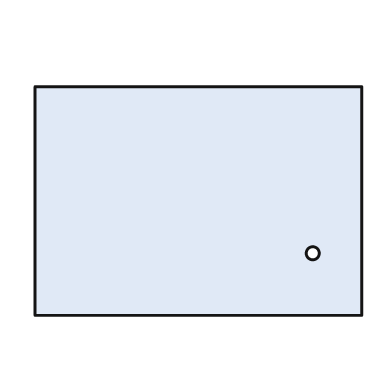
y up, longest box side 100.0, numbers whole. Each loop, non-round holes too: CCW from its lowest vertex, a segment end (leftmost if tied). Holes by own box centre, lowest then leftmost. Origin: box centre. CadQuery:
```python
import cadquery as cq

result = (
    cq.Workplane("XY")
    .moveTo(-50.0, -35.0)
    .lineTo(50.0, -35.0)
    .lineTo(50.0, 35.0)
    .lineTo(-50.0, 35.0)
    .close()
    .moveTo(35.0, -16.0)
    .circle(2.0)
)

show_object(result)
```